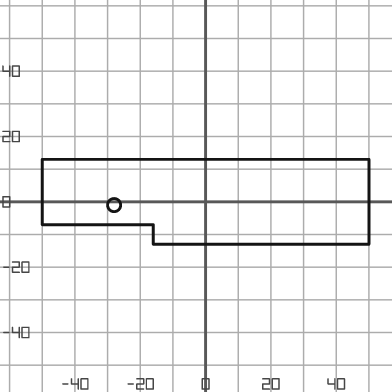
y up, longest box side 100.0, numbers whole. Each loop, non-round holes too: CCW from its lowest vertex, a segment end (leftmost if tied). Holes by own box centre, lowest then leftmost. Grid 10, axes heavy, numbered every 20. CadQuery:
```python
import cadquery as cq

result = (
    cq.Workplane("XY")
    .moveTo(-16.0, -13.0)
    .lineTo(50.0, -13.0)
    .lineTo(50.0, 13.0)
    .lineTo(-50.0, 13.0)
    .lineTo(-50.0, -7.0)
    .lineTo(-16.0, -7.0)
    .close()
    .moveTo(-28.0, -1.0)
    .circle(2.0)
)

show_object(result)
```